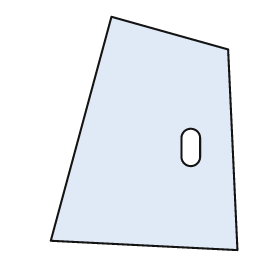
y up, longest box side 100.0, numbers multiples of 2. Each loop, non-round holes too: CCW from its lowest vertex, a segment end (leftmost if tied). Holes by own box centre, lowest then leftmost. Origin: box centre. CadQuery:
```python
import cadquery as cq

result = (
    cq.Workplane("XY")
    .moveTo(40.0, -50.0)
    .lineTo(36.0, 36.0)
    .lineTo(-14.0, 50.0)
    .lineTo(-40.0, -46.0)
    .close()
    .moveTo(16.0, -10.0)
    .threePointArc((20.0, -14.0), (24.0, -10.0))
    .lineTo(24.0, -2.0)
    .threePointArc((20.0, 2.0), (16.0, -2.0))
    .close()
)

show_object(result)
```